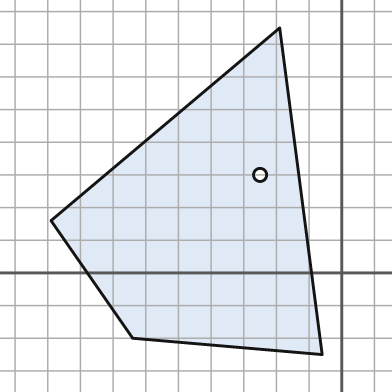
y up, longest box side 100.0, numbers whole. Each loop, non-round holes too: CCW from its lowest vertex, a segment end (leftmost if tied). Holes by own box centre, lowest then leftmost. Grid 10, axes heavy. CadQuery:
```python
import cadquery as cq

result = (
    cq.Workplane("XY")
    .moveTo(-6.0, -25.0)
    .lineTo(-19.0, 75.0)
    .lineTo(-89.0, 16.0)
    .lineTo(-64.0, -20.0)
    .close()
    .moveTo(-25.0, 30.0)
    .circle(2.0)
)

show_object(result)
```